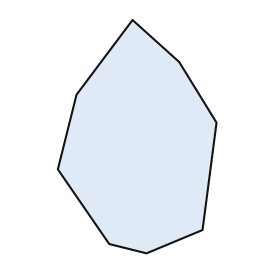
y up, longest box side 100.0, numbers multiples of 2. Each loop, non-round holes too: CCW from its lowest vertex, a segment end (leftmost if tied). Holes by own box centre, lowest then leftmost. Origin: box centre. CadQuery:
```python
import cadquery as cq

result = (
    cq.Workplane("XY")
    .moveTo(4.0, -50.0)
    .lineTo(28.0, -40.0)
    .lineTo(34.0, 6.0)
    .lineTo(18.0, 32.0)
    .lineTo(-2.0, 50.0)
    .lineTo(-26.0, 18.0)
    .lineTo(-34.0, -14.0)
    .lineTo(-12.0, -46.0)
    .close()
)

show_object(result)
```